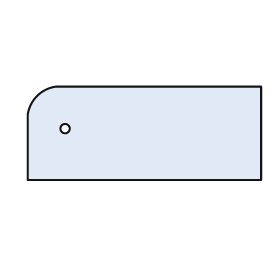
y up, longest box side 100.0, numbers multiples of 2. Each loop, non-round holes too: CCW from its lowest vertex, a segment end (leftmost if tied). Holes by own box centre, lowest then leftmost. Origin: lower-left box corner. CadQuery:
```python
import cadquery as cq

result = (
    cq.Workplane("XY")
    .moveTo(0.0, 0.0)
    .lineTo(100.0, 0.0)
    .lineTo(100.0, 40.0)
    .lineTo(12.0, 40.0)
    .threePointArc((4.0, 36.0), (0.0, 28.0))
    .close()
    .moveTo(16.0, 22.0)
    .circle(2.0)
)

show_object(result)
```